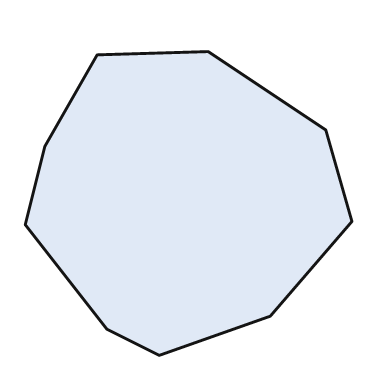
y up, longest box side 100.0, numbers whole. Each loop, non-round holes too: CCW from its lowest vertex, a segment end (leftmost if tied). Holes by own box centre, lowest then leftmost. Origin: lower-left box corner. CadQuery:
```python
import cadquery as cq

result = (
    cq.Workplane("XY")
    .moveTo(41.0, 0.0)
    .lineTo(75.0, 12.0)
    .lineTo(100.0, 41.0)
    .lineTo(92.0, 69.0)
    .lineTo(56.0, 93.0)
    .lineTo(22.0, 92.0)
    .lineTo(6.0, 64.0)
    .lineTo(0.0, 40.0)
    .lineTo(25.0, 8.0)
    .close()
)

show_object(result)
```